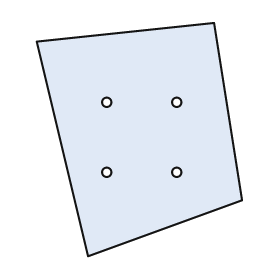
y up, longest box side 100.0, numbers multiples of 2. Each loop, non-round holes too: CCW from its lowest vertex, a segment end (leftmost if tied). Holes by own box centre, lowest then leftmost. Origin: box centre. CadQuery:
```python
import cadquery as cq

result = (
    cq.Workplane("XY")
    .moveTo(-22.0, -50.0)
    .lineTo(44.0, -26.0)
    .lineTo(32.0, 50.0)
    .lineTo(-44.0, 42.0)
    .close()
    .moveTo(-14.0, -14.0)
    .circle(2.0)
    .moveTo(16.0, -14.0)
    .circle(2.0)
    .moveTo(-14.0, 16.0)
    .circle(2.0)
    .moveTo(16.0, 16.0)
    .circle(2.0)
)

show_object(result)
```